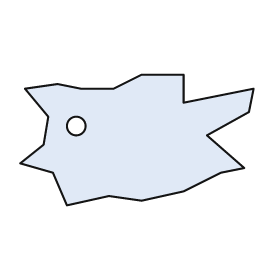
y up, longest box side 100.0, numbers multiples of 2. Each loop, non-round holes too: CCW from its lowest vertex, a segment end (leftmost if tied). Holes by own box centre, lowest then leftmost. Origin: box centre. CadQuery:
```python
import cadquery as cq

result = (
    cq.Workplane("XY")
    .moveTo(-30.0, -28.0)
    .lineTo(-12.0, -24.0)
    .lineTo(2.0, -26.0)
    .lineTo(20.0, -22.0)
    .lineTo(36.0, -14.0)
    .lineTo(46.0, -12.0)
    .lineTo(30.0, 2.0)
    .lineTo(48.0, 12.0)
    .lineTo(50.0, 22.0)
    .lineTo(20.0, 16.0)
    .lineTo(20.0, 28.0)
    .lineTo(2.0, 28.0)
    .lineTo(-10.0, 22.0)
    .lineTo(-24.0, 22.0)
    .lineTo(-34.0, 24.0)
    .lineTo(-48.0, 22.0)
    .lineTo(-38.0, 10.0)
    .lineTo(-40.0, -2.0)
    .lineTo(-50.0, -10.0)
    .lineTo(-36.0, -14.0)
    .close()
    .moveTo(-26.0, 6.0)
    .circle(4.0)
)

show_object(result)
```